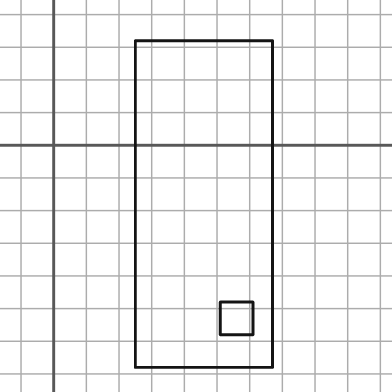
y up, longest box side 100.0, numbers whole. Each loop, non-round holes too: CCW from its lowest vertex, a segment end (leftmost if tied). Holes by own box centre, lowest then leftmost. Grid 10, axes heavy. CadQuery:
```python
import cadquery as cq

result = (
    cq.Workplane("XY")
    .moveTo(25.0, -68.0)
    .lineTo(67.0, -68.0)
    .lineTo(67.0, 32.0)
    .lineTo(25.0, 32.0)
    .close()
    .moveTo(51.0, -58.0)
    .lineTo(61.0, -58.0)
    .lineTo(61.0, -48.0)
    .lineTo(51.0, -48.0)
    .close()
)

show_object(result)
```